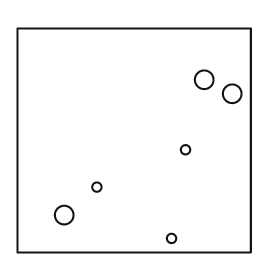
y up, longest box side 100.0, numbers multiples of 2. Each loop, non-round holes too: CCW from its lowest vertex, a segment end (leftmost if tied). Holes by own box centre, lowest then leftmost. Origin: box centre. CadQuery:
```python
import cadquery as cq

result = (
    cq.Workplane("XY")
    .moveTo(-50.0, -48.0)
    .lineTo(50.0, -48.0)
    .lineTo(50.0, 48.0)
    .lineTo(-50.0, 48.0)
    .close()
    .moveTo(16.0, -42.0)
    .circle(2.0)
    .moveTo(-30.0, -32.0)
    .circle(4.0)
    .moveTo(-16.0, -20.0)
    .circle(2.0)
    .moveTo(22.0, -4.0)
    .circle(2.0)
    .moveTo(42.0, 20.0)
    .circle(4.0)
    .moveTo(30.0, 26.0)
    .circle(4.0)
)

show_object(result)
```